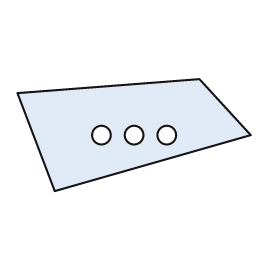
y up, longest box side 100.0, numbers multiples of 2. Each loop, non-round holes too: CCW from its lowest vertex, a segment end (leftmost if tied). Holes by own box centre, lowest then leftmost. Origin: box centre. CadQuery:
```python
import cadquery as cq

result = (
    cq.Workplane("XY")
    .moveTo(-34.0, -24.0)
    .lineTo(50.0, 0.0)
    .lineTo(28.0, 24.0)
    .lineTo(-50.0, 18.0)
    .close()
    .moveTo(-14.0, 0.0)
    .circle(4.0)
    .moveTo(0.0, 0.0)
    .circle(4.0)
    .moveTo(14.0, 0.0)
    .circle(4.0)
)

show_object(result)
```